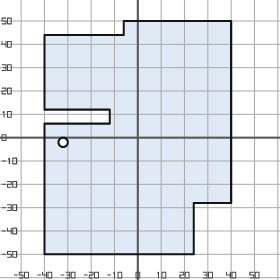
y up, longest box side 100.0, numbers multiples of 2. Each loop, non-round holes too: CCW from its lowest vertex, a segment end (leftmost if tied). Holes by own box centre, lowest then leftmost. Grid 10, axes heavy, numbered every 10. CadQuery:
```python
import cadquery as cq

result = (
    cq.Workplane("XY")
    .moveTo(-40.0, -50.0)
    .lineTo(24.0, -50.0)
    .lineTo(24.0, -28.0)
    .lineTo(40.0, -28.0)
    .lineTo(40.0, 50.0)
    .lineTo(-6.0, 50.0)
    .lineTo(-6.0, 44.0)
    .lineTo(-40.0, 44.0)
    .lineTo(-40.0, 12.0)
    .lineTo(-12.0, 12.0)
    .lineTo(-12.0, 6.0)
    .lineTo(-40.0, 6.0)
    .close()
    .moveTo(-32.0, -2.0)
    .circle(2.0)
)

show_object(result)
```